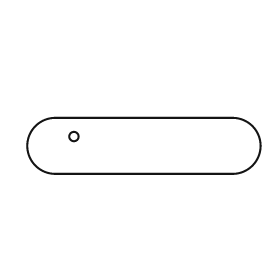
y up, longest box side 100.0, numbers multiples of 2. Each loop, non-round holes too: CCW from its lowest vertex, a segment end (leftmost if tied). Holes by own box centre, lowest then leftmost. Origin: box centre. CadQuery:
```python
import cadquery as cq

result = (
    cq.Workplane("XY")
    .moveTo(-38.0, -12.0)
    .lineTo(38.0, -12.0)
    .threePointArc((50.0, 0.0), (38.0, 12.0))
    .lineTo(-38.0, 12.0)
    .threePointArc((-50.0, 0.0), (-38.0, -12.0))
    .close()
    .moveTo(-30.0, 4.0)
    .circle(2.0)
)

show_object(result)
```